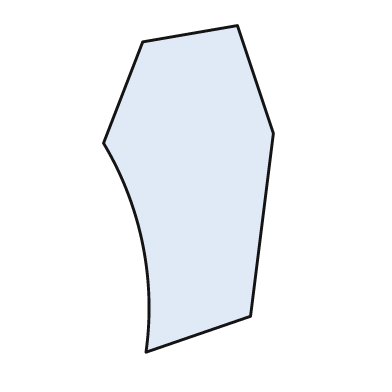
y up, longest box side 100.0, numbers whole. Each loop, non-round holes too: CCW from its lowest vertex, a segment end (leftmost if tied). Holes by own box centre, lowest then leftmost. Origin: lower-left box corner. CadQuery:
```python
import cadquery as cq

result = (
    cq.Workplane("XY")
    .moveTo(13.0, 0.0)
    .lineTo(45.0, 11.0)
    .lineTo(52.0, 67.0)
    .lineTo(41.0, 100.0)
    .lineTo(12.0, 95.0)
    .lineTo(0.0, 64.0)
    .threePointArc((12.0, 33.0), (13.0, 0.0))
    .close()
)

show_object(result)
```